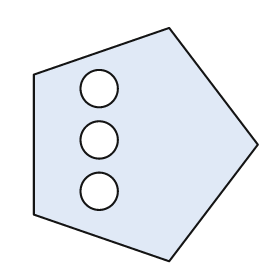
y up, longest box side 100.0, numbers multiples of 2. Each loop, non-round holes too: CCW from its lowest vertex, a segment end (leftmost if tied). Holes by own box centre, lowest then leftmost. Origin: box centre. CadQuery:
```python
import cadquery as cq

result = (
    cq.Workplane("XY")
    .moveTo(10.0, -50.0)
    .lineTo(48.0, 0.0)
    .lineTo(10.0, 50.0)
    .lineTo(-48.0, 30.0)
    .lineTo(-48.0, -30.0)
    .close()
    .moveTo(-20.0, -20.0)
    .circle(8.0)
    .moveTo(-20.0, 2.0)
    .circle(8.0)
    .moveTo(-20.0, 24.0)
    .circle(8.0)
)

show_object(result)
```